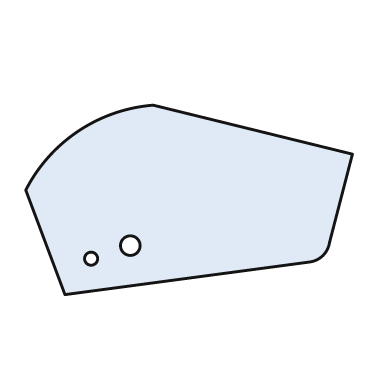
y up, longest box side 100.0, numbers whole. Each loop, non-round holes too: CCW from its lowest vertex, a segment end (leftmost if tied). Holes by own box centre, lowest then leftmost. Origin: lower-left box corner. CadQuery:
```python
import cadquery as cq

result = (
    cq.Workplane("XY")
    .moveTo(12.0, 0.0)
    .lineTo(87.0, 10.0)
    .threePointArc((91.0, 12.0), (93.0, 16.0))
    .lineTo(100.0, 43.0)
    .lineTo(39.0, 58.0)
    .threePointArc((16.0, 50.0), (0.0, 32.0))
    .close()
    .moveTo(20.0, 11.0)
    .circle(2.0)
    .moveTo(32.0, 15.0)
    .circle(3.0)
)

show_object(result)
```